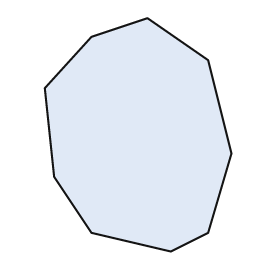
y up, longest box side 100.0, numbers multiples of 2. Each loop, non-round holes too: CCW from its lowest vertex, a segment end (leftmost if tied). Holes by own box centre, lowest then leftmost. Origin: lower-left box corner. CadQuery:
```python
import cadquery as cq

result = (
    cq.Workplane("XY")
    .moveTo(54.0, 0.0)
    .lineTo(70.0, 8.0)
    .lineTo(80.0, 42.0)
    .lineTo(70.0, 82.0)
    .lineTo(44.0, 100.0)
    .lineTo(20.0, 92.0)
    .lineTo(0.0, 70.0)
    .lineTo(4.0, 32.0)
    .lineTo(20.0, 8.0)
    .close()
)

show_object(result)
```